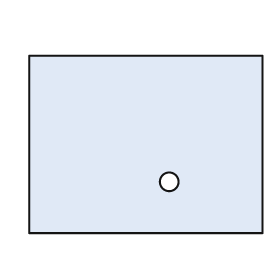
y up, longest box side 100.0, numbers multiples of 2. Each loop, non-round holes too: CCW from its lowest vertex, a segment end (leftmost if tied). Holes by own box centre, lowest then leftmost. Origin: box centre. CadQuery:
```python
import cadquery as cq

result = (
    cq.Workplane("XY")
    .moveTo(-50.0, -38.0)
    .lineTo(50.0, -38.0)
    .lineTo(50.0, 38.0)
    .lineTo(-50.0, 38.0)
    .close()
    .moveTo(10.0, -16.0)
    .circle(4.0)
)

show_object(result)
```